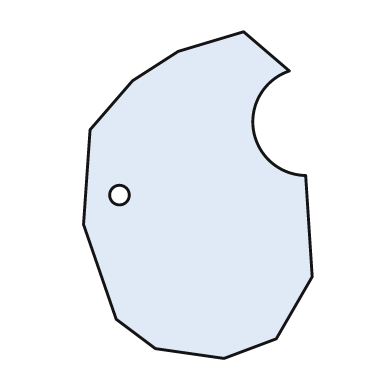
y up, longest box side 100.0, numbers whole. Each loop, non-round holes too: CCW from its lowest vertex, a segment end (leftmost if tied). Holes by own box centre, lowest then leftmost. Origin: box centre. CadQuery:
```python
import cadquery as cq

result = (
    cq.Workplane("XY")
    .moveTo(8.0, -50.0)
    .lineTo(24.0, -44.0)
    .lineTo(35.0, -25.0)
    .lineTo(33.0, 6.0)
    .threePointArc((17.0, 20.0), (28.0, 38.0))
    .lineTo(14.0, 50.0)
    .lineTo(-6.0, 44.0)
    .lineTo(-20.0, 35.0)
    .lineTo(-33.0, 20.0)
    .lineTo(-35.0, -9.0)
    .lineTo(-25.0, -38.0)
    .lineTo(-13.0, -47.0)
    .close()
    .moveTo(-24.0, 0.0)
    .circle(3.0)
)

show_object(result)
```